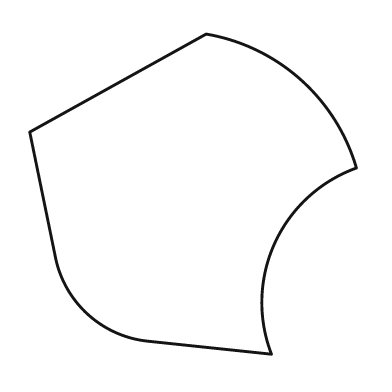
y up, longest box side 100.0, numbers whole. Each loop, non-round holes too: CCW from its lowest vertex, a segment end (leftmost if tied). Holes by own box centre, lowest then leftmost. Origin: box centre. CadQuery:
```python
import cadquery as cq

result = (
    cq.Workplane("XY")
    .moveTo(24.0, -49.0)
    .threePointArc((25.0, -15.0), (50.0, 8.0))
    .threePointArc((33.0, 35.0), (4.0, 49.0))
    .lineTo(-50.0, 19.0)
    .lineTo(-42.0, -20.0)
    .threePointArc((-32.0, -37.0), (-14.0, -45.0))
    .close()
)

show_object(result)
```